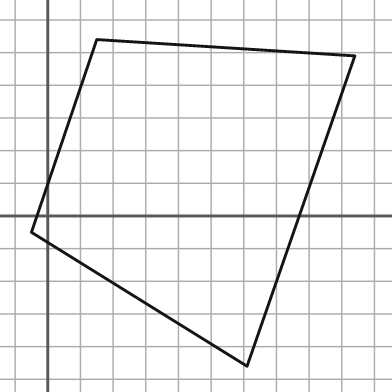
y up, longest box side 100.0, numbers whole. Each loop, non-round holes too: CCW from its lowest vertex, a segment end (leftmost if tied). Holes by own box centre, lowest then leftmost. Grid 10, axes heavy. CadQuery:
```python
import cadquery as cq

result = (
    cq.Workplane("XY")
    .moveTo(61.0, -46.0)
    .lineTo(94.0, 49.0)
    .lineTo(15.0, 54.0)
    .lineTo(-5.0, -5.0)
    .close()
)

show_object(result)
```